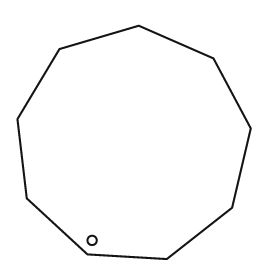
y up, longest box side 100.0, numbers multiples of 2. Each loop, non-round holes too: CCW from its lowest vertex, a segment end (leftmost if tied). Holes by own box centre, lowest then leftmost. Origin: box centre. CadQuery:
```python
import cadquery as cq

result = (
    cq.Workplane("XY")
    .moveTo(14.0, -50.0)
    .lineTo(42.0, -28.0)
    .lineTo(50.0, 6.0)
    .lineTo(34.0, 36.0)
    .lineTo(2.0, 50.0)
    .lineTo(-32.0, 40.0)
    .lineTo(-50.0, 10.0)
    .lineTo(-46.0, -24.0)
    .lineTo(-20.0, -48.0)
    .close()
    .moveTo(-18.0, -42.0)
    .circle(2.0)
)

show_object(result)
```